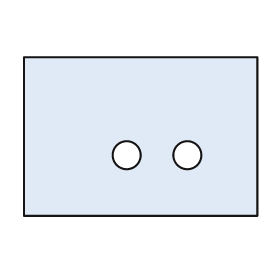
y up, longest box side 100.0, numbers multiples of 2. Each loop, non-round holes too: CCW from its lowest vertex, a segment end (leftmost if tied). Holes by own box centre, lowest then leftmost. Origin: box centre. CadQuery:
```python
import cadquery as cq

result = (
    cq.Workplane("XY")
    .moveTo(-50.0, -34.0)
    .lineTo(50.0, -34.0)
    .lineTo(50.0, 34.0)
    .lineTo(-50.0, 34.0)
    .close()
    .moveTo(-6.0, -8.0)
    .circle(6.0)
    .moveTo(20.0, -8.0)
    .circle(6.0)
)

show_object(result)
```